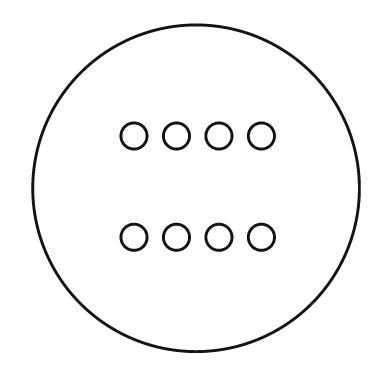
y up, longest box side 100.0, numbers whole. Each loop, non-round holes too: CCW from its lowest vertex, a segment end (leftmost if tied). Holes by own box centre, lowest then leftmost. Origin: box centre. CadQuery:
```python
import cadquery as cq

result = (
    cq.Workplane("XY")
    .moveTo(0.0, 0.0)
    .circle(50.0)
    .moveTo(-19.0, -15.0)
    .circle(4.0)
    .moveTo(-6.0, -15.0)
    .circle(4.0)
    .moveTo(7.0, -15.0)
    .circle(4.0)
    .moveTo(20.0, -15.0)
    .circle(4.0)
    .moveTo(-19.0, 16.0)
    .circle(4.0)
    .moveTo(-6.0, 16.0)
    .circle(4.0)
    .moveTo(7.0, 16.0)
    .circle(4.0)
    .moveTo(20.0, 16.0)
    .circle(4.0)
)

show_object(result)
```